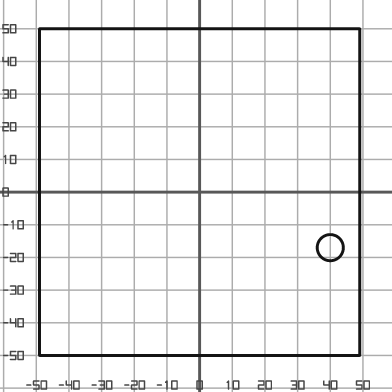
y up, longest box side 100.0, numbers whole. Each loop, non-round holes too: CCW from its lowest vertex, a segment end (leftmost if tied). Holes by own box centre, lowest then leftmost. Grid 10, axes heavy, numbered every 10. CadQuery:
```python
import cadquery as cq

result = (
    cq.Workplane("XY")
    .moveTo(-49.0, -50.0)
    .lineTo(49.0, -50.0)
    .lineTo(49.0, 50.0)
    .lineTo(-49.0, 50.0)
    .close()
    .moveTo(40.0, -17.0)
    .circle(4.0)
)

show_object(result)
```